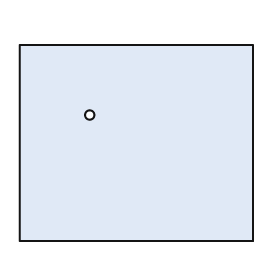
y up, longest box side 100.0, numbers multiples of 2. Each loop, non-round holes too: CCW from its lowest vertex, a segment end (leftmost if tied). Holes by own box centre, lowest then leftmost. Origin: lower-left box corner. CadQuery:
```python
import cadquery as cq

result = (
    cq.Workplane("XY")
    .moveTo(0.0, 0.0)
    .lineTo(100.0, 0.0)
    .lineTo(100.0, 84.0)
    .lineTo(0.0, 84.0)
    .close()
    .moveTo(30.0, 54.0)
    .circle(2.0)
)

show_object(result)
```